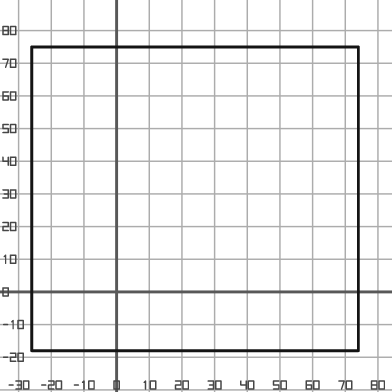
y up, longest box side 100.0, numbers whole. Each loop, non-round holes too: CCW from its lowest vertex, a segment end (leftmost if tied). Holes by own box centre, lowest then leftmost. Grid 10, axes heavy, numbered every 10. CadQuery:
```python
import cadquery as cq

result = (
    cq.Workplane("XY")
    .moveTo(-26.0, -18.0)
    .lineTo(74.0, -18.0)
    .lineTo(74.0, 75.0)
    .lineTo(-26.0, 75.0)
    .close()
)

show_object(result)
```